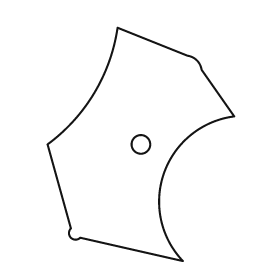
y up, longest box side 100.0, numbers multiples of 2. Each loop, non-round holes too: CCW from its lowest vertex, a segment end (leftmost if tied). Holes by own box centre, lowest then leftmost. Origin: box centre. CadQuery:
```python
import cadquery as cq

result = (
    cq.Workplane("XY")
    .moveTo(18.0, -50.0)
    .threePointArc((10.0, -12.0), (40.0, 12.0))
    .lineTo(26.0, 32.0)
    .threePointArc((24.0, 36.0), (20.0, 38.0))
    .lineTo(-10.0, 50.0)
    .threePointArc((-20.0, 22.0), (-40.0, 0.0))
    .lineTo(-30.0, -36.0)
    .threePointArc((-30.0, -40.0), (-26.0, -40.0))
    .close()
    .moveTo(0.0, 0.0)
    .circle(4.0)
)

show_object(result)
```